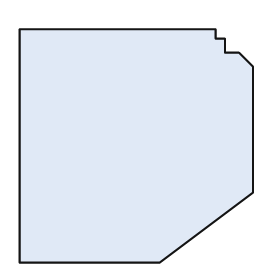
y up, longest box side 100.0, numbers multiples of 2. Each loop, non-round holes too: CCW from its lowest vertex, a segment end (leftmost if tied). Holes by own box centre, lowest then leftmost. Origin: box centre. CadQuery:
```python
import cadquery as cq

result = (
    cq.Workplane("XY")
    .moveTo(-50.0, -50.0)
    .lineTo(10.0, -50.0)
    .lineTo(50.0, -20.0)
    .lineTo(50.0, 34.0)
    .lineTo(44.0, 40.0)
    .lineTo(38.0, 40.0)
    .lineTo(38.0, 46.0)
    .lineTo(34.0, 46.0)
    .lineTo(34.0, 50.0)
    .lineTo(-50.0, 50.0)
    .close()
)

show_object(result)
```